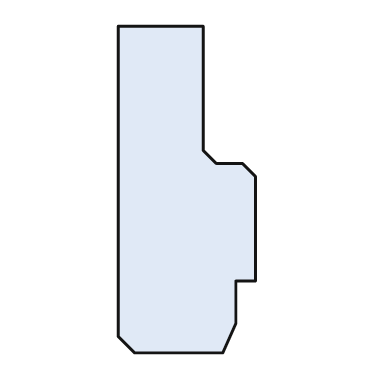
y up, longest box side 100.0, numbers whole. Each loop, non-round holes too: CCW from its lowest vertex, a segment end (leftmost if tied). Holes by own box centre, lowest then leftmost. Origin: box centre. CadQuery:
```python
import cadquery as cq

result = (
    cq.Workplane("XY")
    .moveTo(-16.0, -50.0)
    .lineTo(11.0, -50.0)
    .lineTo(15.0, -41.0)
    .lineTo(15.0, -28.0)
    .lineTo(21.0, -28.0)
    .lineTo(21.0, 4.0)
    .lineTo(17.0, 8.0)
    .lineTo(9.0, 8.0)
    .lineTo(5.0, 12.0)
    .lineTo(5.0, 50.0)
    .lineTo(-21.0, 50.0)
    .lineTo(-21.0, -45.0)
    .close()
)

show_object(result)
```